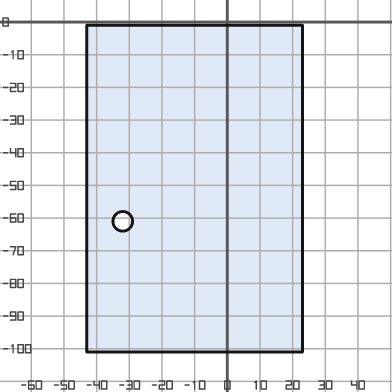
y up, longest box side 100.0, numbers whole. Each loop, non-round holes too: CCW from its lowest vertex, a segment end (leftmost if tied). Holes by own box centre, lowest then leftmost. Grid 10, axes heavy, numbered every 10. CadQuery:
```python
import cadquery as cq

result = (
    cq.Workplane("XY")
    .moveTo(-43.0, -101.0)
    .lineTo(23.0, -101.0)
    .lineTo(23.0, -1.0)
    .lineTo(-43.0, -1.0)
    .close()
    .moveTo(-32.0, -61.0)
    .circle(3.0)
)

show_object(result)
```